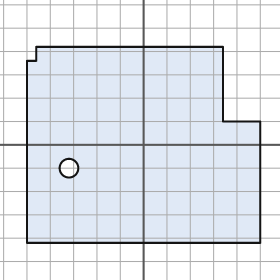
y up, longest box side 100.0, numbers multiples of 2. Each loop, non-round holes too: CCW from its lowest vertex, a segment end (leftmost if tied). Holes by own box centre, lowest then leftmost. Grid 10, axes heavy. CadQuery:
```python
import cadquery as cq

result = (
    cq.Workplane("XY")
    .moveTo(-50.0, -42.0)
    .lineTo(50.0, -42.0)
    .lineTo(50.0, 10.0)
    .lineTo(34.0, 10.0)
    .lineTo(34.0, 42.0)
    .lineTo(-46.0, 42.0)
    .lineTo(-46.0, 36.0)
    .lineTo(-50.0, 36.0)
    .close()
    .moveTo(-32.0, -10.0)
    .circle(4.0)
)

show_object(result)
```